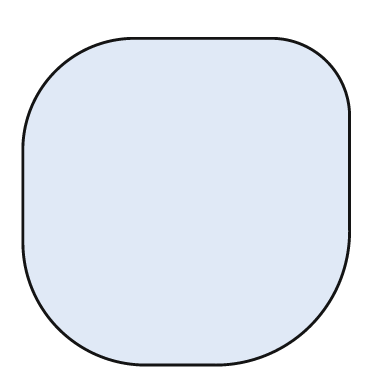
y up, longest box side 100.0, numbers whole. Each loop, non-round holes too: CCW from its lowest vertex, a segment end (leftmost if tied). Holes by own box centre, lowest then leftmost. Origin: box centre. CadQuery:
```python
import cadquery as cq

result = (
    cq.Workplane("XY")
    .moveTo(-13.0, -50.0)
    .lineTo(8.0, -50.0)
    .threePointArc((38.0, -38.0), (50.0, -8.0))
    .lineTo(50.0, 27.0)
    .threePointArc((43.0, 43.0), (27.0, 50.0))
    .lineTo(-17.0, 50.0)
    .threePointArc((-40.0, 40.0), (-50.0, 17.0))
    .lineTo(-50.0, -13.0)
    .threePointArc((-39.0, -39.0), (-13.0, -50.0))
    .close()
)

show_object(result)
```